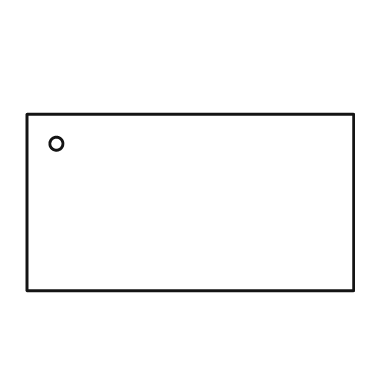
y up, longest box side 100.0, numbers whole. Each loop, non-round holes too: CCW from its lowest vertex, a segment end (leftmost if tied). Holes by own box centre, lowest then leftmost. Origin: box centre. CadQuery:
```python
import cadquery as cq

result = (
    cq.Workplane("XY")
    .moveTo(-50.0, -27.0)
    .lineTo(50.0, -27.0)
    .lineTo(50.0, 27.0)
    .lineTo(-50.0, 27.0)
    .close()
    .moveTo(-41.0, 18.0)
    .circle(2.0)
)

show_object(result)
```